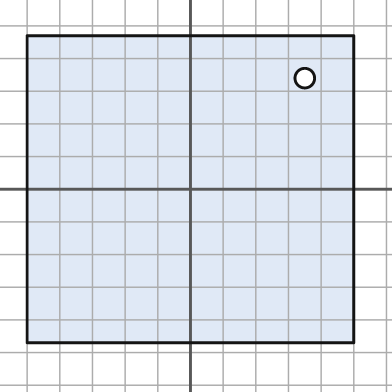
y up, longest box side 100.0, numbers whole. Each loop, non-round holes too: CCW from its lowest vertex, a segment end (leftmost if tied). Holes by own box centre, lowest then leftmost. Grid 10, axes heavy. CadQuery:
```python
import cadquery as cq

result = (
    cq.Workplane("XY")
    .moveTo(-50.0, -47.0)
    .lineTo(50.0, -47.0)
    .lineTo(50.0, 47.0)
    .lineTo(-50.0, 47.0)
    .close()
    .moveTo(35.0, 34.0)
    .circle(3.0)
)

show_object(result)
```